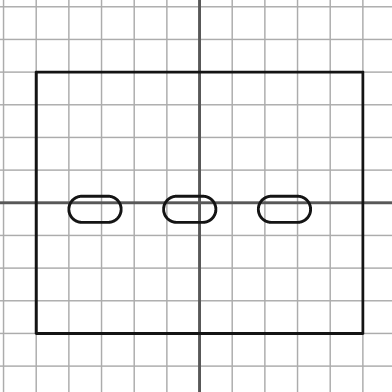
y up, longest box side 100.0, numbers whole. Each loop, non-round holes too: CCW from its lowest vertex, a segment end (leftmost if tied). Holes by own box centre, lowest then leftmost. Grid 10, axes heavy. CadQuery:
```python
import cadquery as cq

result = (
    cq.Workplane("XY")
    .moveTo(-50.0, -40.0)
    .lineTo(50.0, -40.0)
    .lineTo(50.0, 40.0)
    .lineTo(-50.0, 40.0)
    .close()
    .moveTo(-36.0, -6.0)
    .lineTo(-28.0, -6.0)
    .threePointArc((-24.0, -2.0), (-28.0, 2.0))
    .lineTo(-36.0, 2.0)
    .threePointArc((-40.0, -2.0), (-36.0, -6.0))
    .close()
    .moveTo(-7.0, -6.0)
    .lineTo(1.0, -6.0)
    .threePointArc((5.0, -2.0), (1.0, 2.0))
    .lineTo(-7.0, 2.0)
    .threePointArc((-11.0, -2.0), (-7.0, -6.0))
    .close()
    .moveTo(22.0, -6.0)
    .lineTo(30.0, -6.0)
    .threePointArc((34.0, -2.0), (30.0, 2.0))
    .lineTo(22.0, 2.0)
    .threePointArc((18.0, -2.0), (22.0, -6.0))
    .close()
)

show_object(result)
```